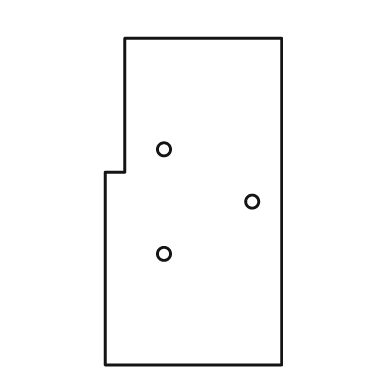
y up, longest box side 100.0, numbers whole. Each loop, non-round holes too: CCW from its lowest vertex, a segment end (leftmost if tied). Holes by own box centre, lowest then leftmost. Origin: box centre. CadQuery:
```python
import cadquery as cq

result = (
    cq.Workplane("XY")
    .moveTo(-27.0, -50.0)
    .lineTo(27.0, -50.0)
    .lineTo(27.0, 50.0)
    .lineTo(-21.0, 50.0)
    .lineTo(-21.0, 9.0)
    .lineTo(-27.0, 9.0)
    .close()
    .moveTo(-9.0, -16.0)
    .circle(2.0)
    .moveTo(18.0, 0.0)
    .circle(2.0)
    .moveTo(-9.0, 16.0)
    .circle(2.0)
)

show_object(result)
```